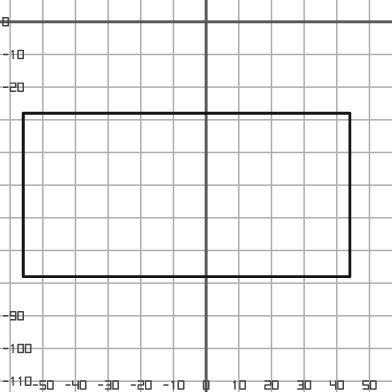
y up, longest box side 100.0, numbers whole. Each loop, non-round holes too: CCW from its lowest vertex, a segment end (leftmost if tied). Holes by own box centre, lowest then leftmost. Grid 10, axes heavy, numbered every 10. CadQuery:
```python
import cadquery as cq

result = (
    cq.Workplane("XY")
    .moveTo(-56.0, -78.0)
    .lineTo(44.0, -78.0)
    .lineTo(44.0, -28.0)
    .lineTo(-56.0, -28.0)
    .close()
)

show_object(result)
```